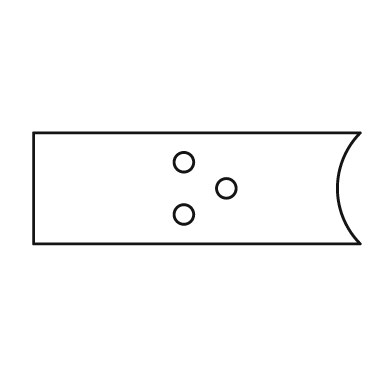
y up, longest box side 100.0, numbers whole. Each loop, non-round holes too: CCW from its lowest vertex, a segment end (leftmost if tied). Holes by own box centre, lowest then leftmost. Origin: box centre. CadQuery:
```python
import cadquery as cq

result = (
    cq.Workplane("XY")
    .moveTo(-50.0, -17.0)
    .lineTo(50.0, -17.0)
    .threePointArc((43.0, 0.0), (50.0, 17.0))
    .lineTo(-50.0, 17.0)
    .close()
    .moveTo(-4.0, -8.0)
    .circle(3.0)
    .moveTo(9.0, 0.0)
    .circle(3.0)
    .moveTo(-4.0, 8.0)
    .circle(3.0)
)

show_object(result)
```